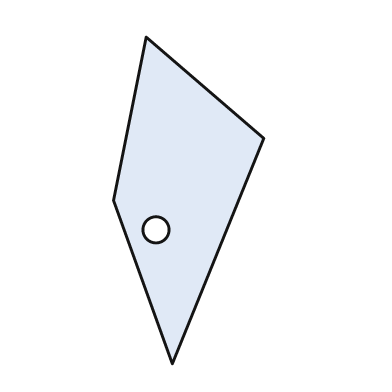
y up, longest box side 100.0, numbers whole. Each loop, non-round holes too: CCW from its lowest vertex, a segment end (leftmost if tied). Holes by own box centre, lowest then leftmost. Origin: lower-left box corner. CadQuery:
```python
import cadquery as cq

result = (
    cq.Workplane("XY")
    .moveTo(18.0, 0.0)
    .lineTo(46.0, 69.0)
    .lineTo(10.0, 100.0)
    .lineTo(0.0, 50.0)
    .close()
    .moveTo(13.0, 41.0)
    .circle(4.0)
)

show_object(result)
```